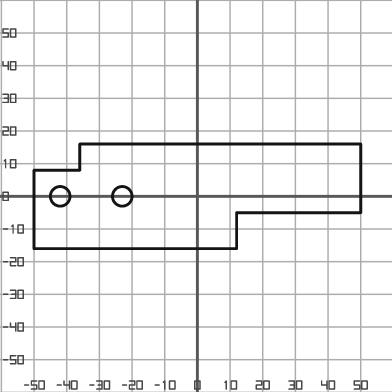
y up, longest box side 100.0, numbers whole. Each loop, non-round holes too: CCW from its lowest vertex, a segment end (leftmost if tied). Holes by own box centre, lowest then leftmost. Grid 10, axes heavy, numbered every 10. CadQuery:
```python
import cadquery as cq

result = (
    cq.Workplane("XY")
    .moveTo(-50.0, -16.0)
    .lineTo(12.0, -16.0)
    .lineTo(12.0, -5.0)
    .lineTo(50.0, -5.0)
    .lineTo(50.0, 16.0)
    .lineTo(-36.0, 16.0)
    .lineTo(-36.0, 8.0)
    .lineTo(-50.0, 8.0)
    .close()
    .moveTo(-42.0, 0.0)
    .circle(3.0)
    .moveTo(-23.0, 0.0)
    .circle(3.0)
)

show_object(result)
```